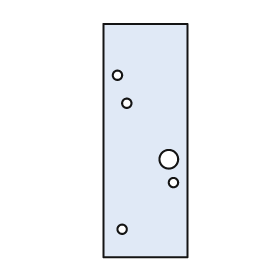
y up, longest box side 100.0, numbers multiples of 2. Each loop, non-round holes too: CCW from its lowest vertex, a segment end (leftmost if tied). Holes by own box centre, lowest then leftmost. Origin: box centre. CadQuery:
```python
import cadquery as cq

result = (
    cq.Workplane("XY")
    .moveTo(-18.0, -50.0)
    .lineTo(18.0, -50.0)
    .lineTo(18.0, 50.0)
    .lineTo(-18.0, 50.0)
    .close()
    .moveTo(-10.0, -38.0)
    .circle(2.0)
    .moveTo(12.0, -18.0)
    .circle(2.0)
    .moveTo(10.0, -8.0)
    .circle(4.0)
    .moveTo(-8.0, 16.0)
    .circle(2.0)
    .moveTo(-12.0, 28.0)
    .circle(2.0)
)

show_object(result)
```